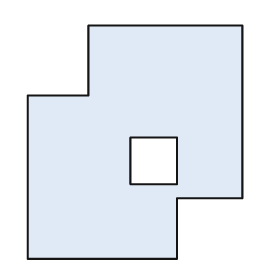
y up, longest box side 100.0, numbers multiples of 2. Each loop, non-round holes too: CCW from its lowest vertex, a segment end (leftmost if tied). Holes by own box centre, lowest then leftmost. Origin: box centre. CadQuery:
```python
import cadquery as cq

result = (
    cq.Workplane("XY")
    .moveTo(-46.0, -50.0)
    .lineTo(18.0, -50.0)
    .lineTo(18.0, -24.0)
    .lineTo(46.0, -24.0)
    .lineTo(46.0, 50.0)
    .lineTo(-20.0, 50.0)
    .lineTo(-20.0, 20.0)
    .lineTo(-46.0, 20.0)
    .close()
    .moveTo(-2.0, -18.0)
    .lineTo(18.0, -18.0)
    .lineTo(18.0, 2.0)
    .lineTo(-2.0, 2.0)
    .close()
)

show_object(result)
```